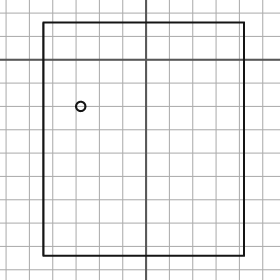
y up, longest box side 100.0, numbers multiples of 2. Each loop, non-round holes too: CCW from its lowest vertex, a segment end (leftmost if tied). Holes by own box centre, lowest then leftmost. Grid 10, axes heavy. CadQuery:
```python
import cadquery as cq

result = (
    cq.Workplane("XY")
    .moveTo(-44.0, -84.0)
    .lineTo(42.0, -84.0)
    .lineTo(42.0, 16.0)
    .lineTo(-44.0, 16.0)
    .close()
    .moveTo(-28.0, -20.0)
    .circle(2.0)
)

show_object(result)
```